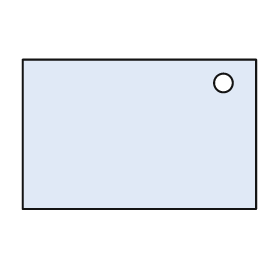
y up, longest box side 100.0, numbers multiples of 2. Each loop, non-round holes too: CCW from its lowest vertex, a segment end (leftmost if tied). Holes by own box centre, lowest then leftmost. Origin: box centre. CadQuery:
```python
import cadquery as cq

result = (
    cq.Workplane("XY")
    .moveTo(-50.0, -32.0)
    .lineTo(50.0, -32.0)
    .lineTo(50.0, 32.0)
    .lineTo(-50.0, 32.0)
    .close()
    .moveTo(36.0, 22.0)
    .circle(4.0)
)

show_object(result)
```